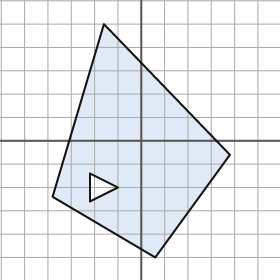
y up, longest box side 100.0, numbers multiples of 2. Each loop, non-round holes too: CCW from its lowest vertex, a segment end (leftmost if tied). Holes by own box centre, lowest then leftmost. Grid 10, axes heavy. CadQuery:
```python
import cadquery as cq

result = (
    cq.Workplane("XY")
    .moveTo(6.0, -50.0)
    .lineTo(38.0, -6.0)
    .lineTo(-16.0, 50.0)
    .lineTo(-38.0, -24.0)
    .close()
    .moveTo(-22.0, -26.0)
    .lineTo(-10.0, -20.0)
    .lineTo(-22.0, -14.0)
    .close()
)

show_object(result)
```